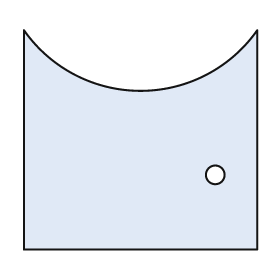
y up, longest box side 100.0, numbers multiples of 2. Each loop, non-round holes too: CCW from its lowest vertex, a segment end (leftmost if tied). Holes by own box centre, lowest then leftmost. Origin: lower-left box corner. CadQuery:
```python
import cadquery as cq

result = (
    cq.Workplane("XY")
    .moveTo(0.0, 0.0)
    .lineTo(100.0, 0.0)
    .lineTo(100.0, 94.0)
    .threePointArc((50.0, 68.0), (0.0, 94.0))
    .close()
    .moveTo(82.0, 32.0)
    .circle(4.0)
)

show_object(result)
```